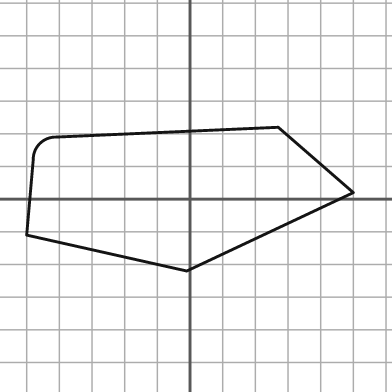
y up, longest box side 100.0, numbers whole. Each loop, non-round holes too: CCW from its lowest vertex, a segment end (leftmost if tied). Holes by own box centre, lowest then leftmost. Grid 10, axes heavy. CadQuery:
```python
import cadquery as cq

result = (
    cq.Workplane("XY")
    .moveTo(-1.0, -22.0)
    .lineTo(50.0, 2.0)
    .lineTo(27.0, 22.0)
    .lineTo(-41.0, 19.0)
    .threePointArc((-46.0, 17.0), (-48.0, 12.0))
    .lineTo(-50.0, -11.0)
    .close()
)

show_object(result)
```